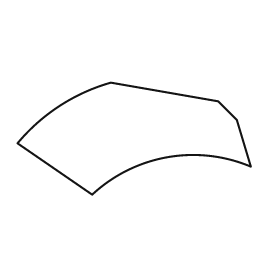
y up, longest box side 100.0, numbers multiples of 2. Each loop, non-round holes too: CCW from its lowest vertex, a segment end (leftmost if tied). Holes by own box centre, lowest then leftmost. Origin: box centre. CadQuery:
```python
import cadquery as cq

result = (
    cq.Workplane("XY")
    .moveTo(-18.0, -24.0)
    .threePointArc((14.0, -8.0), (50.0, -12.0))
    .lineTo(44.0, 8.0)
    .lineTo(36.0, 16.0)
    .lineTo(-10.0, 24.0)
    .threePointArc((-32.0, 14.0), (-50.0, -2.0))
    .close()
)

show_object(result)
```